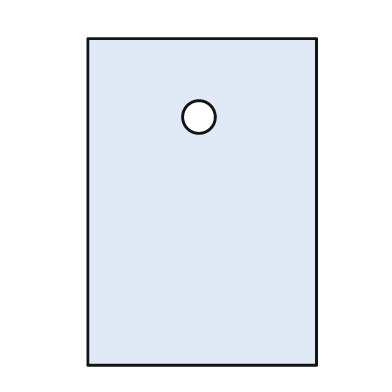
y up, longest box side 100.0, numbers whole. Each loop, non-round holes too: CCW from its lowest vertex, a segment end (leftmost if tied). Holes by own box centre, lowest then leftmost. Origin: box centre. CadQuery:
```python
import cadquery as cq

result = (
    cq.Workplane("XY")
    .moveTo(-35.0, -50.0)
    .lineTo(35.0, -50.0)
    .lineTo(35.0, 50.0)
    .lineTo(-35.0, 50.0)
    .close()
    .moveTo(-1.0, 26.0)
    .circle(5.0)
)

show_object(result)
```